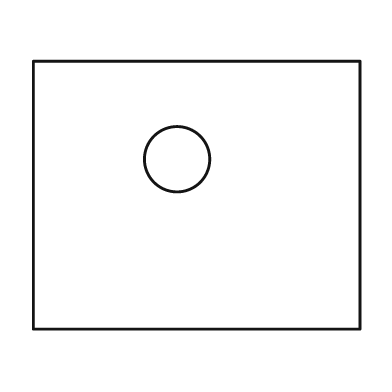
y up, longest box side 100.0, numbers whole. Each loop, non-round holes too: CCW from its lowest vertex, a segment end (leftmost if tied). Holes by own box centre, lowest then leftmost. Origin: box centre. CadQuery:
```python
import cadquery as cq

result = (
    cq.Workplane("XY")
    .moveTo(-50.0, -41.0)
    .lineTo(50.0, -41.0)
    .lineTo(50.0, 41.0)
    .lineTo(-50.0, 41.0)
    .close()
    .moveTo(-6.0, 11.0)
    .circle(10.0)
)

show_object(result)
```